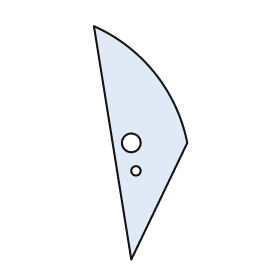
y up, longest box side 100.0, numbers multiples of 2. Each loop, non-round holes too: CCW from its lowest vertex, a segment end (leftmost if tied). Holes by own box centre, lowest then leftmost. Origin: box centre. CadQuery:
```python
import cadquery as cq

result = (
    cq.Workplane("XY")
    .moveTo(-4.0, -50.0)
    .lineTo(20.0, 0.0)
    .threePointArc((6.0, 30.0), (-20.0, 50.0))
    .close()
    .moveTo(-2.0, -12.0)
    .circle(2.0)
    .moveTo(-4.0, 0.0)
    .circle(4.0)
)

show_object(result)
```